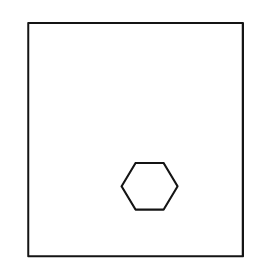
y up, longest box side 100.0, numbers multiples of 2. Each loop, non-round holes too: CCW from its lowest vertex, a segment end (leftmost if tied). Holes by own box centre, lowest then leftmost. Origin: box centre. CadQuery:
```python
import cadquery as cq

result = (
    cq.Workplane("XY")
    .moveTo(-46.0, -50.0)
    .lineTo(46.0, -50.0)
    .lineTo(46.0, 50.0)
    .lineTo(-46.0, 50.0)
    .close()
    .moveTo(0.0, -30.0)
    .lineTo(12.0, -30.0)
    .lineTo(18.0, -20.0)
    .lineTo(12.0, -10.0)
    .lineTo(0.0, -10.0)
    .lineTo(-6.0, -20.0)
    .close()
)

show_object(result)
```